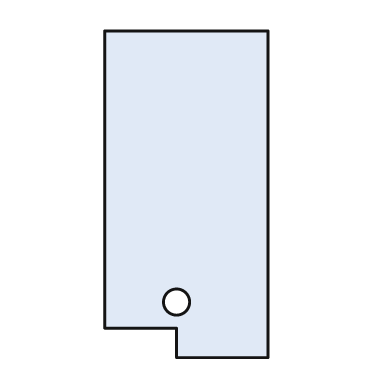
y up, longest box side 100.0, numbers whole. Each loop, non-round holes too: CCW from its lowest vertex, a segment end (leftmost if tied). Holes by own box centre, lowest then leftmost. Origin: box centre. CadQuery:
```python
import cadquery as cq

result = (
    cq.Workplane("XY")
    .moveTo(-3.0, -50.0)
    .lineTo(25.0, -50.0)
    .lineTo(25.0, 50.0)
    .lineTo(-25.0, 50.0)
    .lineTo(-25.0, -41.0)
    .lineTo(-3.0, -41.0)
    .close()
    .moveTo(-3.0, -33.0)
    .circle(4.0)
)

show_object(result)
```